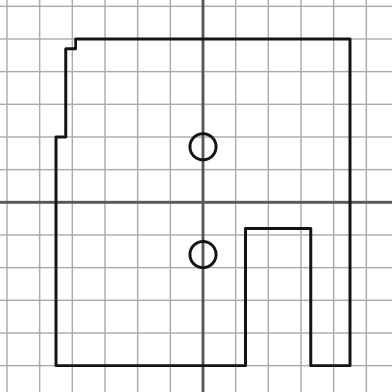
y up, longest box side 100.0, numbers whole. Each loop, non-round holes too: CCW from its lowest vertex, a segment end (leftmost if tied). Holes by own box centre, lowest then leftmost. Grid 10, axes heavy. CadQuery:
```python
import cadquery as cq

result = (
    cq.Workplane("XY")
    .moveTo(-45.0, -50.0)
    .lineTo(13.0, -50.0)
    .lineTo(13.0, -8.0)
    .lineTo(33.0, -8.0)
    .lineTo(33.0, -50.0)
    .lineTo(45.0, -50.0)
    .lineTo(45.0, 50.0)
    .lineTo(-39.0, 50.0)
    .lineTo(-39.0, 47.0)
    .lineTo(-42.0, 47.0)
    .lineTo(-42.0, 20.0)
    .lineTo(-45.0, 20.0)
    .close()
    .moveTo(0.0, -16.0)
    .circle(4.0)
    .moveTo(0.0, 17.0)
    .circle(4.0)
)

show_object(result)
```